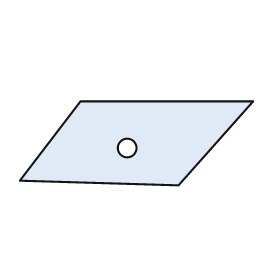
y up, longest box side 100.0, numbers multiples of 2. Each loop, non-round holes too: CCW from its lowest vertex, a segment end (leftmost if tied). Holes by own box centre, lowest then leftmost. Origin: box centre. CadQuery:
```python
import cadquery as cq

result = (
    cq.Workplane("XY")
    .moveTo(18.0, -18.0)
    .lineTo(50.0, 18.0)
    .lineTo(-24.0, 18.0)
    .lineTo(-50.0, -16.0)
    .close()
    .moveTo(-4.0, -2.0)
    .circle(4.0)
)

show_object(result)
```